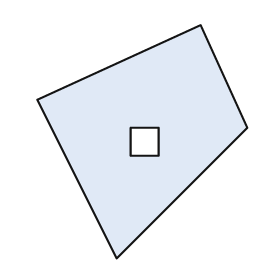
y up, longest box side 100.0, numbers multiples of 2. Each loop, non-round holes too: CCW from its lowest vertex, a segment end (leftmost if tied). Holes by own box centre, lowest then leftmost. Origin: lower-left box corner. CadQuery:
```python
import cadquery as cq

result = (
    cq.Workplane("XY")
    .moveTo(34.0, 0.0)
    .lineTo(90.0, 56.0)
    .lineTo(70.0, 100.0)
    .lineTo(0.0, 68.0)
    .close()
    .moveTo(40.0, 44.0)
    .lineTo(52.0, 44.0)
    .lineTo(52.0, 56.0)
    .lineTo(40.0, 56.0)
    .close()
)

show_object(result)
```